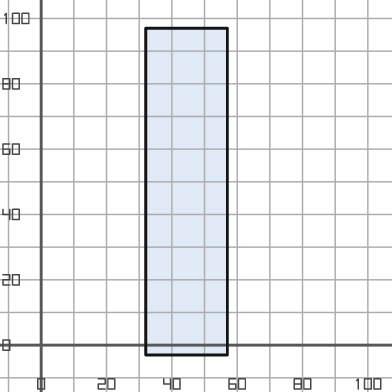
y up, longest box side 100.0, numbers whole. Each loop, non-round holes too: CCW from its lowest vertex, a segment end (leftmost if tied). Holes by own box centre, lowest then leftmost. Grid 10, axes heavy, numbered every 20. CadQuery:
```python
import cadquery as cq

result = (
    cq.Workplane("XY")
    .moveTo(32.0, -3.0)
    .lineTo(57.0, -3.0)
    .lineTo(57.0, 97.0)
    .lineTo(32.0, 97.0)
    .close()
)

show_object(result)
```